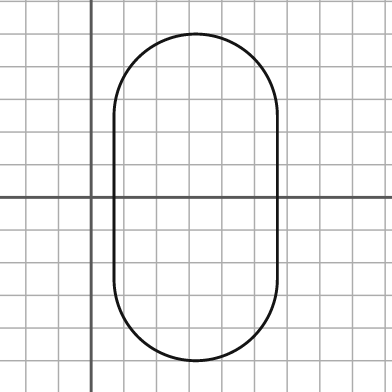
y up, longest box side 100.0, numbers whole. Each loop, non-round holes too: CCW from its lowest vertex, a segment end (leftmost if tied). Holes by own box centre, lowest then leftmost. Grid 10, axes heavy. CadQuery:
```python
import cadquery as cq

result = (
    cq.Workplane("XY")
    .moveTo(7.0, -25.0)
    .threePointArc((32.0, -50.0), (57.0, -25.0))
    .lineTo(57.0, 25.0)
    .threePointArc((32.0, 50.0), (7.0, 25.0))
    .close()
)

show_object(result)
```